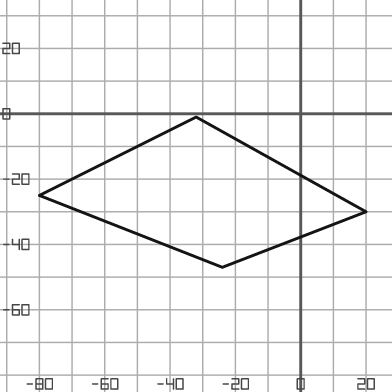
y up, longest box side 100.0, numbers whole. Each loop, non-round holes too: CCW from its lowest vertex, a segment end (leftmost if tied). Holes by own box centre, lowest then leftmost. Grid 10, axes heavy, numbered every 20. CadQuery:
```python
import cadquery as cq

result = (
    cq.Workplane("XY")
    .moveTo(-24.0, -47.0)
    .lineTo(20.0, -30.0)
    .lineTo(-32.0, -1.0)
    .lineTo(-80.0, -25.0)
    .close()
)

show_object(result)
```